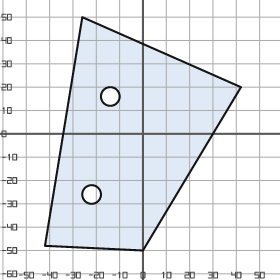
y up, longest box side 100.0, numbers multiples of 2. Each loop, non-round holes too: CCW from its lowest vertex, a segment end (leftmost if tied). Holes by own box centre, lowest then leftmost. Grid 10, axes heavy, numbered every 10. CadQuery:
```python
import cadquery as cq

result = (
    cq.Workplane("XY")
    .moveTo(0.0, -50.0)
    .lineTo(42.0, 20.0)
    .lineTo(-26.0, 50.0)
    .lineTo(-42.0, -48.0)
    .close()
    .moveTo(-22.0, -26.0)
    .circle(4.0)
    .moveTo(-14.0, 16.0)
    .circle(4.0)
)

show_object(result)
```